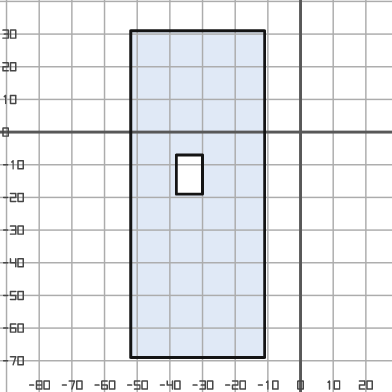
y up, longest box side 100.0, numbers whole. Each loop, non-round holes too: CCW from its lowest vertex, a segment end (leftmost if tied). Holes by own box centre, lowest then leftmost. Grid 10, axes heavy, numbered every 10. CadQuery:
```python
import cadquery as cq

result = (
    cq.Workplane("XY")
    .moveTo(-52.0, -69.0)
    .lineTo(-11.0, -69.0)
    .lineTo(-11.0, 31.0)
    .lineTo(-52.0, 31.0)
    .close()
    .moveTo(-38.0, -19.0)
    .lineTo(-30.0, -19.0)
    .lineTo(-30.0, -7.0)
    .lineTo(-38.0, -7.0)
    .close()
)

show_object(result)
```